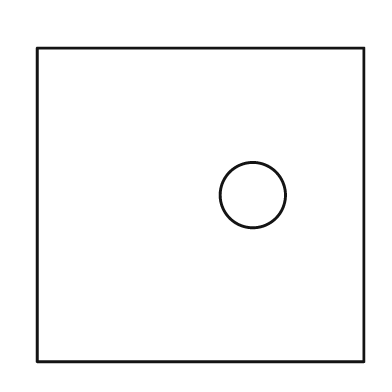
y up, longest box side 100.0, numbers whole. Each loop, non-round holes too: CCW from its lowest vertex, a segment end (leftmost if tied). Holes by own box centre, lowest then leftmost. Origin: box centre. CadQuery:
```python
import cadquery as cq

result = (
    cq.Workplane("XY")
    .moveTo(-50.0, -48.0)
    .lineTo(50.0, -48.0)
    .lineTo(50.0, 48.0)
    .lineTo(-50.0, 48.0)
    .close()
    .moveTo(16.0, 3.0)
    .circle(10.0)
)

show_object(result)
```